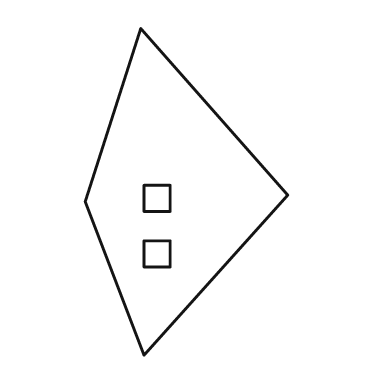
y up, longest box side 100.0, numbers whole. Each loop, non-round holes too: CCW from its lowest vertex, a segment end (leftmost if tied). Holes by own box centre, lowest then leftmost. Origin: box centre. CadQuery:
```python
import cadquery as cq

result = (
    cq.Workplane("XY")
    .moveTo(-13.0, -50.0)
    .lineTo(31.0, -1.0)
    .lineTo(-14.0, 50.0)
    .lineTo(-31.0, -3.0)
    .close()
    .moveTo(-13.0, -23.0)
    .lineTo(-5.0, -23.0)
    .lineTo(-5.0, -15.0)
    .lineTo(-13.0, -15.0)
    .close()
    .moveTo(-13.0, -6.0)
    .lineTo(-5.0, -6.0)
    .lineTo(-5.0, 2.0)
    .lineTo(-13.0, 2.0)
    .close()
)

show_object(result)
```